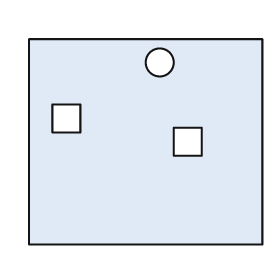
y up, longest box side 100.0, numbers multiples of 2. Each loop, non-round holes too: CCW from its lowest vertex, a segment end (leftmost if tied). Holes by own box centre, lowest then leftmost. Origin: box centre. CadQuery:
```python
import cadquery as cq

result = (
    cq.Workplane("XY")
    .moveTo(-50.0, -44.0)
    .lineTo(50.0, -44.0)
    .lineTo(50.0, 44.0)
    .lineTo(-50.0, 44.0)
    .close()
    .moveTo(12.0, -6.0)
    .lineTo(24.0, -6.0)
    .lineTo(24.0, 6.0)
    .lineTo(12.0, 6.0)
    .close()
    .moveTo(-40.0, 4.0)
    .lineTo(-28.0, 4.0)
    .lineTo(-28.0, 16.0)
    .lineTo(-40.0, 16.0)
    .close()
    .moveTo(6.0, 34.0)
    .circle(6.0)
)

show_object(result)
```